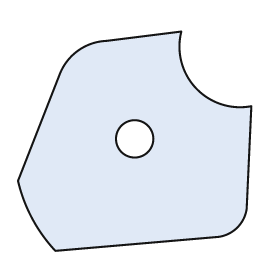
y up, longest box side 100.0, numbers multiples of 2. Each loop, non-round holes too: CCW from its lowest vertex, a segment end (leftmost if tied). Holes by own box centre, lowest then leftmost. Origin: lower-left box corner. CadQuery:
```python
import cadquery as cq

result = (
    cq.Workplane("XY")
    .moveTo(16.0, 0.0)
    .lineTo(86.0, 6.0)
    .threePointArc((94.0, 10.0), (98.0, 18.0))
    .lineTo(100.0, 62.0)
    .threePointArc((76.0, 70.0), (70.0, 94.0))
    .lineTo(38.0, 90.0)
    .threePointArc((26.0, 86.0), (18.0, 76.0))
    .lineTo(0.0, 30.0)
    .threePointArc((6.0, 14.0), (16.0, 0.0))
    .close()
    .moveTo(50.0, 48.0)
    .circle(8.0)
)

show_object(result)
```